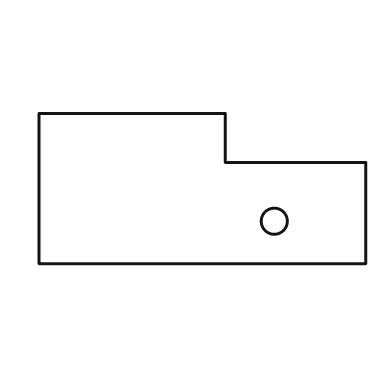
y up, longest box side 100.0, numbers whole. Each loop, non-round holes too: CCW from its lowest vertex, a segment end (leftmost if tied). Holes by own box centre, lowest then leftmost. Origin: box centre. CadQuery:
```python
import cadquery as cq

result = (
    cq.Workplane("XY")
    .moveTo(-50.0, -23.0)
    .lineTo(50.0, -23.0)
    .lineTo(50.0, 8.0)
    .lineTo(7.0, 8.0)
    .lineTo(7.0, 23.0)
    .lineTo(-50.0, 23.0)
    .close()
    .moveTo(22.0, -10.0)
    .circle(4.0)
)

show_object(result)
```